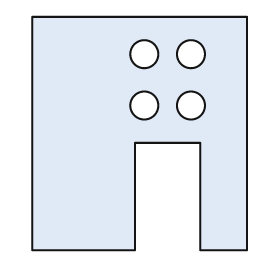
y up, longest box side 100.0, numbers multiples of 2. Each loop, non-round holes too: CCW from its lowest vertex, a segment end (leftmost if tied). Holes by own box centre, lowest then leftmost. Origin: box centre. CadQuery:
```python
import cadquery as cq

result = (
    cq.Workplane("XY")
    .moveTo(-46.0, -50.0)
    .lineTo(-2.0, -50.0)
    .lineTo(-2.0, -4.0)
    .lineTo(26.0, -4.0)
    .lineTo(26.0, -50.0)
    .lineTo(46.0, -50.0)
    .lineTo(46.0, 50.0)
    .lineTo(-46.0, 50.0)
    .close()
    .moveTo(2.0, 12.0)
    .circle(6.0)
    .moveTo(22.0, 12.0)
    .circle(6.0)
    .moveTo(2.0, 34.0)
    .circle(6.0)
    .moveTo(22.0, 34.0)
    .circle(6.0)
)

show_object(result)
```